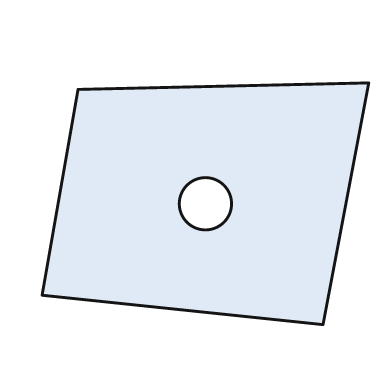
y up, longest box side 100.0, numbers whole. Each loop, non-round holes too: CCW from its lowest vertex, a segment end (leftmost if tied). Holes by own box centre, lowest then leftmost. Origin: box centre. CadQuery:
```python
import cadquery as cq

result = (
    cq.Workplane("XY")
    .moveTo(36.0, -37.0)
    .lineTo(50.0, 37.0)
    .lineTo(-39.0, 35.0)
    .lineTo(-50.0, -28.0)
    .close()
    .moveTo(0.0, 0.0)
    .circle(8.0)
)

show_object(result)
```